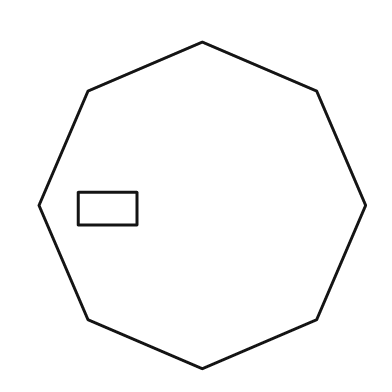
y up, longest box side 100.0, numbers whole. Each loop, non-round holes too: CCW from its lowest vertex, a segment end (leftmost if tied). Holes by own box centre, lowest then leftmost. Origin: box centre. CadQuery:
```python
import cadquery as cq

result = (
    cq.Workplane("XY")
    .moveTo(0.0, -50.0)
    .lineTo(35.0, -35.0)
    .lineTo(50.0, 0.0)
    .lineTo(35.0, 35.0)
    .lineTo(0.0, 50.0)
    .lineTo(-35.0, 35.0)
    .lineTo(-50.0, 0.0)
    .lineTo(-35.0, -35.0)
    .close()
    .moveTo(-38.0, -6.0)
    .lineTo(-20.0, -6.0)
    .lineTo(-20.0, 4.0)
    .lineTo(-38.0, 4.0)
    .close()
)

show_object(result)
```